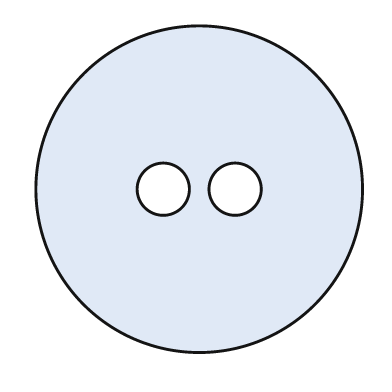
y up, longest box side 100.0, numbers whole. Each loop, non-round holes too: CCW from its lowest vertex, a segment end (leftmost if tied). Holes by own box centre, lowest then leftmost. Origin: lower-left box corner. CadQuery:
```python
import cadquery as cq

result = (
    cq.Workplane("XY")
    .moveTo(50.0, 50.0)
    .circle(50.0)
    .moveTo(39.0, 50.0)
    .circle(8.0)
    .moveTo(61.0, 50.0)
    .circle(8.0)
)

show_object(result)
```